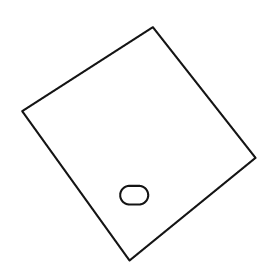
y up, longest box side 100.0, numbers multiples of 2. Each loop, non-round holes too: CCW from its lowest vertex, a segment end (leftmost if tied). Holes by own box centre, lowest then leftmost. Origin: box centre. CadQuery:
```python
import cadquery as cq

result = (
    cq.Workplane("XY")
    .moveTo(-4.0, -50.0)
    .lineTo(50.0, -6.0)
    .lineTo(6.0, 50.0)
    .lineTo(-50.0, 14.0)
    .close()
    .moveTo(-4.0, -26.0)
    .lineTo(0.0, -26.0)
    .threePointArc((4.0, -22.0), (0.0, -18.0))
    .lineTo(-4.0, -18.0)
    .threePointArc((-8.0, -22.0), (-4.0, -26.0))
    .close()
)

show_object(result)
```